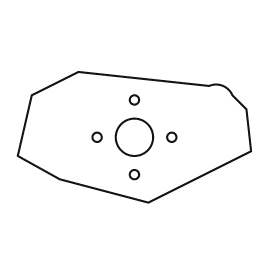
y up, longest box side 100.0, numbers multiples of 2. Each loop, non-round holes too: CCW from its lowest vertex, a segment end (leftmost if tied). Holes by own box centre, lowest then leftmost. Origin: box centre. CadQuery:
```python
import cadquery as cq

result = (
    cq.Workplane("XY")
    .moveTo(6.0, -28.0)
    .lineTo(50.0, -6.0)
    .lineTo(48.0, 12.0)
    .lineTo(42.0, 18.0)
    .threePointArc((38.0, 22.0), (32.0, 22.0))
    .lineTo(-24.0, 28.0)
    .lineTo(-44.0, 18.0)
    .lineTo(-50.0, -8.0)
    .lineTo(-32.0, -18.0)
    .close()
    .moveTo(0.0, -16.0)
    .circle(2.0)
    .moveTo(-16.0, 0.0)
    .circle(2.0)
    .moveTo(0.0, 0.0)
    .circle(8.0)
    .moveTo(16.0, 0.0)
    .circle(2.0)
    .moveTo(0.0, 16.0)
    .circle(2.0)
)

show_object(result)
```